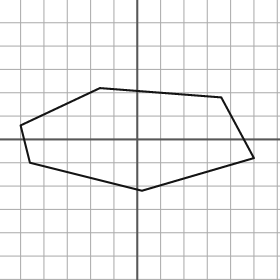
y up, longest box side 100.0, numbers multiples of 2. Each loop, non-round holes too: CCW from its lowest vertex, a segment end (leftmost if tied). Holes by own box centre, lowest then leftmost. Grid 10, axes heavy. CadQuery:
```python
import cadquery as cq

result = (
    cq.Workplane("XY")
    .moveTo(2.0, -22.0)
    .lineTo(50.0, -8.0)
    .lineTo(36.0, 18.0)
    .lineTo(-16.0, 22.0)
    .lineTo(-50.0, 6.0)
    .lineTo(-46.0, -10.0)
    .close()
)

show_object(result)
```